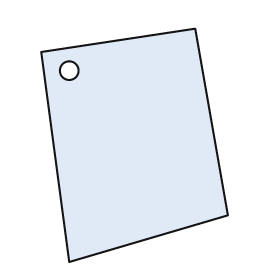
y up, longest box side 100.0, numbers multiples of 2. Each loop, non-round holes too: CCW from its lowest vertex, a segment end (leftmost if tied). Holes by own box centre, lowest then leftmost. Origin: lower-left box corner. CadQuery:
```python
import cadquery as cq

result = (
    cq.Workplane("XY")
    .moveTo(12.0, 0.0)
    .lineTo(80.0, 20.0)
    .lineTo(66.0, 100.0)
    .lineTo(0.0, 90.0)
    .close()
    .moveTo(12.0, 82.0)
    .circle(4.0)
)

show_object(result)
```